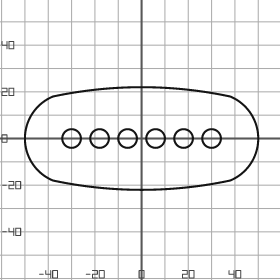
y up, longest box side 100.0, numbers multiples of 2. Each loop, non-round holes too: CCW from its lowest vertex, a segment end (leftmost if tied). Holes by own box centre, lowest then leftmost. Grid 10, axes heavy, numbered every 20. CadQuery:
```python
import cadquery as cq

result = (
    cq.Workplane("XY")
    .moveTo(-38.0, -18.0)
    .threePointArc((0.0, -22.0), (38.0, -18.0))
    .threePointArc((50.0, 0.0), (38.0, 18.0))
    .threePointArc((0.0, 22.0), (-38.0, 18.0))
    .threePointArc((-50.0, 0.0), (-38.0, -18.0))
    .close()
    .moveTo(-30.0, 0.0)
    .circle(4.0)
    .moveTo(-18.0, 0.0)
    .circle(4.0)
    .moveTo(-6.0, 0.0)
    .circle(4.0)
    .moveTo(6.0, 0.0)
    .circle(4.0)
    .moveTo(18.0, 0.0)
    .circle(4.0)
    .moveTo(30.0, 0.0)
    .circle(4.0)
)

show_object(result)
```